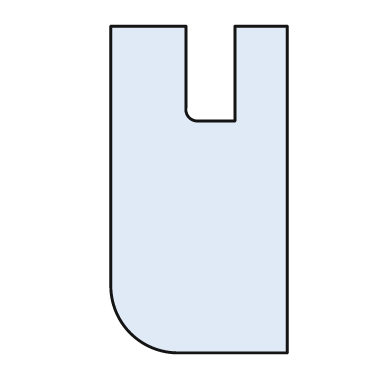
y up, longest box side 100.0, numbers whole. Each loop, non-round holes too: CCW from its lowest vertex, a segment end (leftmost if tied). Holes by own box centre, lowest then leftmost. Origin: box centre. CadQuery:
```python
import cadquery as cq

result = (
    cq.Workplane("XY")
    .moveTo(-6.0, -50.0)
    .lineTo(27.0, -50.0)
    .lineTo(27.0, 50.0)
    .lineTo(11.0, 50.0)
    .lineTo(11.0, 21.0)
    .lineTo(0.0, 21.0)
    .threePointArc((-3.0, 22.0), (-4.0, 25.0))
    .lineTo(-4.0, 50.0)
    .lineTo(-27.0, 50.0)
    .lineTo(-27.0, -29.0)
    .threePointArc((-21.0, -44.0), (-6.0, -50.0))
    .close()
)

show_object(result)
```